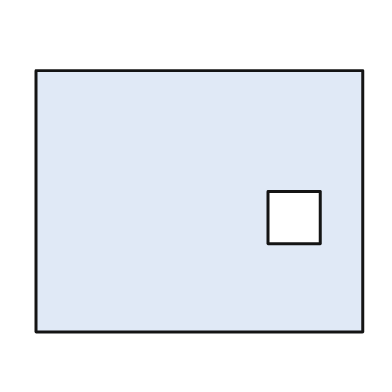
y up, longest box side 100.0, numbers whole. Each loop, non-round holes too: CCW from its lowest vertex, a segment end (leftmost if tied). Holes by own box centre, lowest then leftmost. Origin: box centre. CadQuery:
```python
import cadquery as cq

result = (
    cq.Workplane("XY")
    .moveTo(-50.0, -40.0)
    .lineTo(50.0, -40.0)
    .lineTo(50.0, 40.0)
    .lineTo(-50.0, 40.0)
    .close()
    .moveTo(21.0, -13.0)
    .lineTo(37.0, -13.0)
    .lineTo(37.0, 3.0)
    .lineTo(21.0, 3.0)
    .close()
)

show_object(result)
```